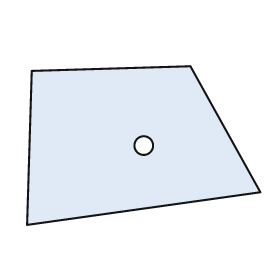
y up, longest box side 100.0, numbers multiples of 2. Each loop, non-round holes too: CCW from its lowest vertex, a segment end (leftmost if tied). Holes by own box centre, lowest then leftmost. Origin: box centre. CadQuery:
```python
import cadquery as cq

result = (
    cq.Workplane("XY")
    .moveTo(-50.0, -34.0)
    .lineTo(50.0, -20.0)
    .lineTo(20.0, 34.0)
    .lineTo(-48.0, 32.0)
    .close()
    .moveTo(0.0, 0.0)
    .circle(4.0)
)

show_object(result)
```